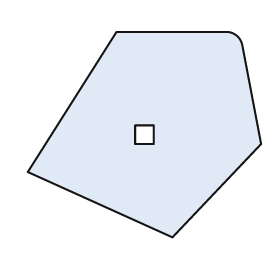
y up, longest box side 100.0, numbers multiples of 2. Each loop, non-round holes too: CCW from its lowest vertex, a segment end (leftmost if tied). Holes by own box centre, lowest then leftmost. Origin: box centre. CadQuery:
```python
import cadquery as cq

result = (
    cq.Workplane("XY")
    .moveTo(12.0, -44.0)
    .lineTo(50.0, -4.0)
    .lineTo(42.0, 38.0)
    .threePointArc((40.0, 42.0), (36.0, 44.0))
    .lineTo(-12.0, 44.0)
    .lineTo(-50.0, -16.0)
    .close()
    .moveTo(-4.0, -4.0)
    .lineTo(4.0, -4.0)
    .lineTo(4.0, 4.0)
    .lineTo(-4.0, 4.0)
    .close()
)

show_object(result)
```